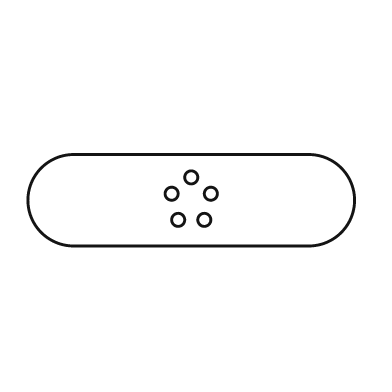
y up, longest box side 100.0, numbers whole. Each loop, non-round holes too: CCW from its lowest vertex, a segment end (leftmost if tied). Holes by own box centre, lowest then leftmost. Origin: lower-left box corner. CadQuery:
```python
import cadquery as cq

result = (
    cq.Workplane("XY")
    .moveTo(14.0, 0.0)
    .lineTo(86.0, 0.0)
    .threePointArc((100.0, 14.0), (86.0, 28.0))
    .lineTo(14.0, 28.0)
    .threePointArc((0.0, 14.0), (14.0, 0.0))
    .close()
    .moveTo(46.0, 8.0)
    .circle(2.0)
    .moveTo(54.0, 8.0)
    .circle(2.0)
    .moveTo(44.0, 16.0)
    .circle(2.0)
    .moveTo(56.0, 16.0)
    .circle(2.0)
    .moveTo(50.0, 21.0)
    .circle(2.0)
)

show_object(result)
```